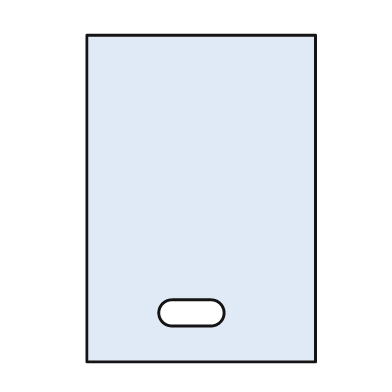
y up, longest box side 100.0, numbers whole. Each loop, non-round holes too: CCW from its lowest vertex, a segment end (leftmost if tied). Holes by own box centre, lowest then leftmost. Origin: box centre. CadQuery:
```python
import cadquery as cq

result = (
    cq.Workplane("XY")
    .moveTo(-35.0, -50.0)
    .lineTo(35.0, -50.0)
    .lineTo(35.0, 50.0)
    .lineTo(-35.0, 50.0)
    .close()
    .moveTo(-9.0, -39.0)
    .lineTo(3.0, -39.0)
    .threePointArc((7.0, -35.0), (3.0, -31.0))
    .lineTo(-9.0, -31.0)
    .threePointArc((-13.0, -35.0), (-9.0, -39.0))
    .close()
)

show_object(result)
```